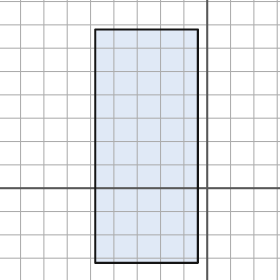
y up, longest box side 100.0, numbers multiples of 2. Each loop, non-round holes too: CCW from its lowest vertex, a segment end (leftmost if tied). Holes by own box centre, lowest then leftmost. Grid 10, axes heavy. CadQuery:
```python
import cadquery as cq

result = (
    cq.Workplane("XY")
    .moveTo(-48.0, -32.0)
    .lineTo(-4.0, -32.0)
    .lineTo(-4.0, 68.0)
    .lineTo(-48.0, 68.0)
    .close()
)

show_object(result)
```